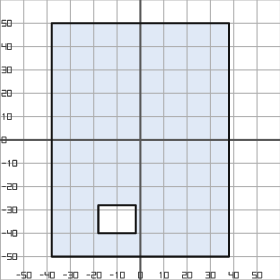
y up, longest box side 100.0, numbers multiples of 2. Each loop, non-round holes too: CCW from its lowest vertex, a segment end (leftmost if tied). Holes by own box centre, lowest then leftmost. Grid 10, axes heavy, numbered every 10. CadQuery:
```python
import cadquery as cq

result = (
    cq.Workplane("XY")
    .moveTo(-38.0, -50.0)
    .lineTo(38.0, -50.0)
    .lineTo(38.0, 50.0)
    .lineTo(-38.0, 50.0)
    .close()
    .moveTo(-18.0, -40.0)
    .lineTo(-2.0, -40.0)
    .lineTo(-2.0, -28.0)
    .lineTo(-18.0, -28.0)
    .close()
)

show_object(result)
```